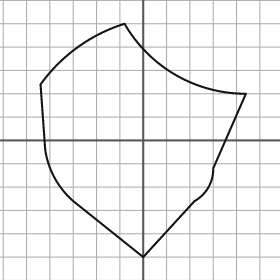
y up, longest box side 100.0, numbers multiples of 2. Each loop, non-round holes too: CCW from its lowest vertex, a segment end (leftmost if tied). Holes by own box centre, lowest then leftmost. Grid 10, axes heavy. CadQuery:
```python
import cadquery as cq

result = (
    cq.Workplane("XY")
    .moveTo(0.0, -50.0)
    .lineTo(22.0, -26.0)
    .threePointArc((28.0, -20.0), (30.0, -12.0))
    .lineTo(44.0, 20.0)
    .threePointArc((14.0, 28.0), (-8.0, 50.0))
    .threePointArc((-28.0, 40.0), (-44.0, 24.0))
    .lineTo(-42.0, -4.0)
    .threePointArc((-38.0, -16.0), (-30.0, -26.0))
    .close()
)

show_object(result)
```